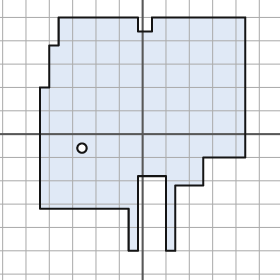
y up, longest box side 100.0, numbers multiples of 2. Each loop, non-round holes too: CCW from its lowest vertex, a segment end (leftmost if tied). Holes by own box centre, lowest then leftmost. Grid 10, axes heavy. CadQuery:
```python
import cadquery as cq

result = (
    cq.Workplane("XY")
    .moveTo(-6.0, -50.0)
    .lineTo(-2.0, -50.0)
    .lineTo(-2.0, -18.0)
    .lineTo(10.0, -18.0)
    .lineTo(10.0, -50.0)
    .lineTo(14.0, -50.0)
    .lineTo(14.0, -22.0)
    .lineTo(26.0, -22.0)
    .lineTo(26.0, -10.0)
    .lineTo(44.0, -10.0)
    .lineTo(44.0, 50.0)
    .lineTo(4.0, 50.0)
    .lineTo(4.0, 44.0)
    .lineTo(-2.0, 44.0)
    .lineTo(-2.0, 50.0)
    .lineTo(-36.0, 50.0)
    .lineTo(-36.0, 38.0)
    .lineTo(-40.0, 38.0)
    .lineTo(-40.0, 20.0)
    .lineTo(-44.0, 20.0)
    .lineTo(-44.0, -32.0)
    .lineTo(-6.0, -32.0)
    .close()
    .moveTo(-26.0, -6.0)
    .circle(2.0)
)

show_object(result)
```